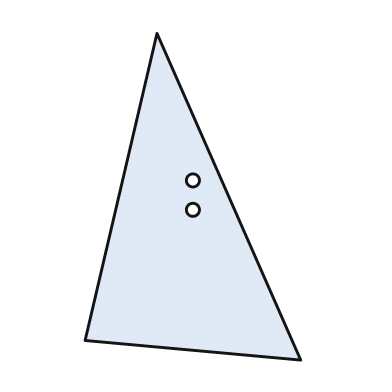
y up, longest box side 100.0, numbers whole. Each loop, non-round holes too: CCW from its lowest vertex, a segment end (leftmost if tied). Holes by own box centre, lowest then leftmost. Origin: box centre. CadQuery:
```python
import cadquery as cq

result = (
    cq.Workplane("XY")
    .moveTo(33.0, -50.0)
    .lineTo(-11.0, 50.0)
    .lineTo(-33.0, -44.0)
    .close()
    .moveTo(0.0, -4.0)
    .circle(2.0)
    .moveTo(0.0, 5.0)
    .circle(2.0)
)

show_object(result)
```